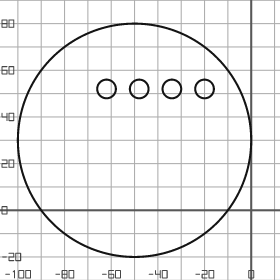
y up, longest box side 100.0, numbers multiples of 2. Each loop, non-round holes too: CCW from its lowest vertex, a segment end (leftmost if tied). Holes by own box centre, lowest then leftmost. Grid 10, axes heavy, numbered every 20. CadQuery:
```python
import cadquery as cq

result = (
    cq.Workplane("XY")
    .moveTo(-50.0, 30.0)
    .circle(50.0)
    .moveTo(-62.0, 52.0)
    .circle(4.0)
    .moveTo(-48.0, 52.0)
    .circle(4.0)
    .moveTo(-34.0, 52.0)
    .circle(4.0)
    .moveTo(-20.0, 52.0)
    .circle(4.0)
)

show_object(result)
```